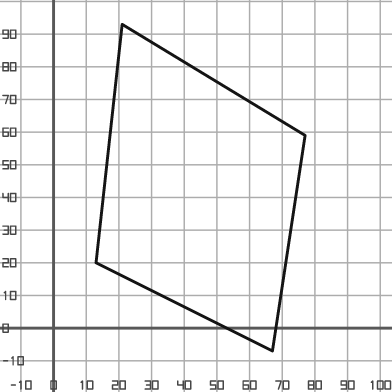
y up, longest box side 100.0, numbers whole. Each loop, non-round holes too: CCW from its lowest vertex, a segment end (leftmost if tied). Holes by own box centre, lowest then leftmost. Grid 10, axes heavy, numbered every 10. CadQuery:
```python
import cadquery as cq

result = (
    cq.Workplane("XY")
    .moveTo(67.0, -7.0)
    .lineTo(77.0, 59.0)
    .lineTo(21.0, 93.0)
    .lineTo(13.0, 20.0)
    .close()
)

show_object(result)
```